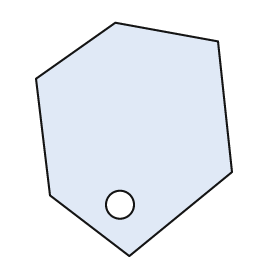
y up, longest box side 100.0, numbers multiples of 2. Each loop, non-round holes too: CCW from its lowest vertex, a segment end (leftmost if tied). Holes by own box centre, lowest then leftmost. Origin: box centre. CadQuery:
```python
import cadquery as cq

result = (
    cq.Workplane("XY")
    .moveTo(-2.0, -50.0)
    .lineTo(42.0, -14.0)
    .lineTo(36.0, 42.0)
    .lineTo(-8.0, 50.0)
    .lineTo(-42.0, 26.0)
    .lineTo(-36.0, -24.0)
    .close()
    .moveTo(-6.0, -28.0)
    .circle(6.0)
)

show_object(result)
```